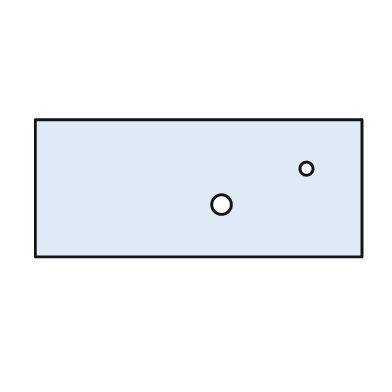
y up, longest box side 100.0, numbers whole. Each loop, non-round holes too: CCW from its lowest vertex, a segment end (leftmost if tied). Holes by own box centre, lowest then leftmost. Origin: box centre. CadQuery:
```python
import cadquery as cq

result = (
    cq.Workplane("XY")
    .moveTo(-50.0, -21.0)
    .lineTo(50.0, -21.0)
    .lineTo(50.0, 21.0)
    .lineTo(-50.0, 21.0)
    .close()
    .moveTo(7.0, -5.0)
    .circle(3.0)
    .moveTo(33.0, 6.0)
    .circle(2.0)
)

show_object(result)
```